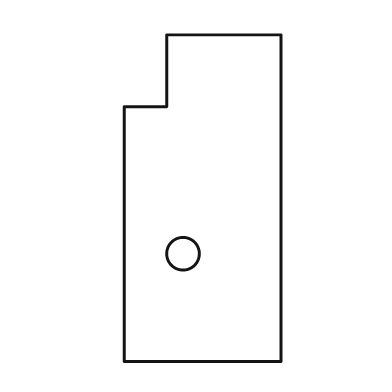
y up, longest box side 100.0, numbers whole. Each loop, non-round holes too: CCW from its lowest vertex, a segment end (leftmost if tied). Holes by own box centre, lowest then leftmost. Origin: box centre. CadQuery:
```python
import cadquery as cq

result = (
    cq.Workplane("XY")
    .moveTo(-24.0, -50.0)
    .lineTo(24.0, -50.0)
    .lineTo(24.0, 50.0)
    .lineTo(-11.0, 50.0)
    .lineTo(-11.0, 28.0)
    .lineTo(-24.0, 28.0)
    .close()
    .moveTo(-6.0, -17.0)
    .circle(5.0)
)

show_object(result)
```